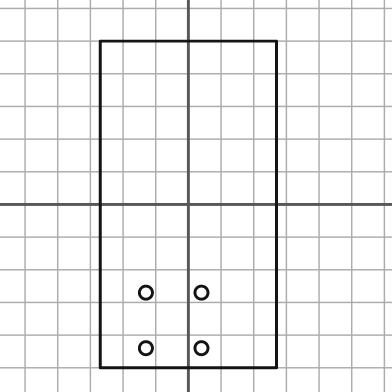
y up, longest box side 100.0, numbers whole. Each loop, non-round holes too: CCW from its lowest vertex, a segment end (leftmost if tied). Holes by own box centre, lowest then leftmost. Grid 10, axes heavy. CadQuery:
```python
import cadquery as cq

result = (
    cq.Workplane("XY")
    .moveTo(-27.0, -50.0)
    .lineTo(27.0, -50.0)
    .lineTo(27.0, 50.0)
    .lineTo(-27.0, 50.0)
    .close()
    .moveTo(-13.0, -44.0)
    .circle(2.0)
    .moveTo(4.0, -44.0)
    .circle(2.0)
    .moveTo(-13.0, -27.0)
    .circle(2.0)
    .moveTo(4.0, -27.0)
    .circle(2.0)
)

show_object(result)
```